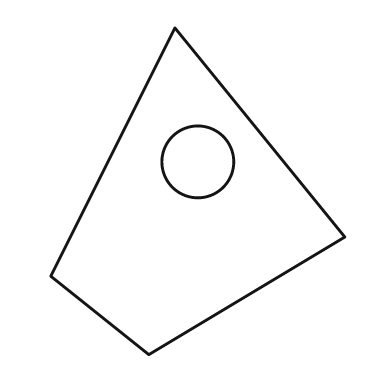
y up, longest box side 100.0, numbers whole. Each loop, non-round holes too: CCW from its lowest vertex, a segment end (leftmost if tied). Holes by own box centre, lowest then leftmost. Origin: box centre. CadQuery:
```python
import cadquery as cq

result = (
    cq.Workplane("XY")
    .moveTo(-15.0, -50.0)
    .lineTo(45.0, -14.0)
    .lineTo(-7.0, 50.0)
    .lineTo(-45.0, -26.0)
    .close()
    .moveTo(0.0, 9.0)
    .circle(11.0)
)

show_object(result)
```